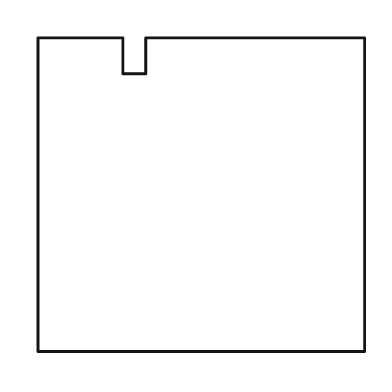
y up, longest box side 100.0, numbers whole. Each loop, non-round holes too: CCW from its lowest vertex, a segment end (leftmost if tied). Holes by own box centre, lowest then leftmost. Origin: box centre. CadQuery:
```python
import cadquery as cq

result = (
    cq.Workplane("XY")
    .moveTo(-50.0, -48.0)
    .lineTo(50.0, -48.0)
    .lineTo(50.0, 48.0)
    .lineTo(-17.0, 48.0)
    .lineTo(-17.0, 37.0)
    .lineTo(-24.0, 37.0)
    .lineTo(-24.0, 48.0)
    .lineTo(-50.0, 48.0)
    .close()
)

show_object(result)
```